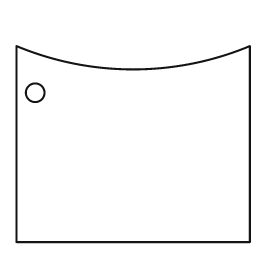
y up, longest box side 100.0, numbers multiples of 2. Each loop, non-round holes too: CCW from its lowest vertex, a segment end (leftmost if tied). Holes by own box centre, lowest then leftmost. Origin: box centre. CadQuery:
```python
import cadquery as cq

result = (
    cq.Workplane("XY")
    .moveTo(-50.0, -42.0)
    .lineTo(50.0, -42.0)
    .lineTo(50.0, 42.0)
    .threePointArc((0.0, 32.0), (-50.0, 42.0))
    .close()
    .moveTo(-42.0, 22.0)
    .circle(4.0)
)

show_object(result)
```